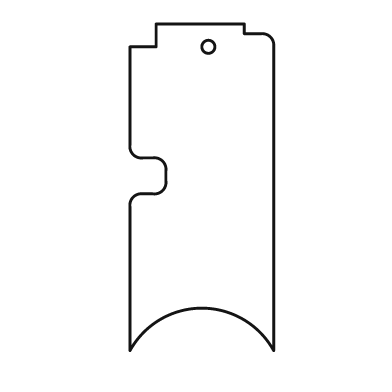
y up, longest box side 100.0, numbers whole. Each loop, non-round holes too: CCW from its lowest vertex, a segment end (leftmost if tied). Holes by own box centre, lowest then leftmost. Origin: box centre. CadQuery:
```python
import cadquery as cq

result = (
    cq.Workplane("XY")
    .moveTo(-22.0, -50.0)
    .threePointArc((0.0, -37.0), (22.0, -50.0))
    .lineTo(22.0, 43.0)
    .threePointArc((21.0, 46.0), (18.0, 47.0))
    .lineTo(13.0, 47.0)
    .lineTo(13.0, 50.0)
    .lineTo(-14.0, 50.0)
    .lineTo(-14.0, 43.0)
    .lineTo(-22.0, 43.0)
    .lineTo(-22.0, 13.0)
    .threePointArc((-21.0, 10.0), (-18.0, 9.0))
    .lineTo(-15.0, 9.0)
    .threePointArc((-12.0, 8.0), (-11.0, 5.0))
    .lineTo(-11.0, 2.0)
    .threePointArc((-12.0, -1.0), (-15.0, -2.0))
    .lineTo(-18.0, -2.0)
    .threePointArc((-21.0, -3.0), (-22.0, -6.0))
    .close()
    .moveTo(2.0, 43.0)
    .circle(2.0)
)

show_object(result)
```